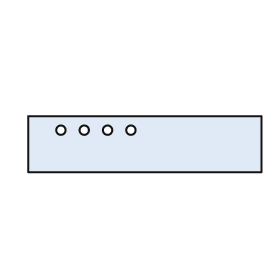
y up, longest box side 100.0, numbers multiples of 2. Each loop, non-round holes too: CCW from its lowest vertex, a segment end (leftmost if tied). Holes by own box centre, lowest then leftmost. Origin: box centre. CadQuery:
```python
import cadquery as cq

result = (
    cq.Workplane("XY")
    .moveTo(-50.0, -12.0)
    .lineTo(50.0, -12.0)
    .lineTo(50.0, 12.0)
    .lineTo(-50.0, 12.0)
    .close()
    .moveTo(-36.0, 6.0)
    .circle(2.0)
    .moveTo(-26.0, 6.0)
    .circle(2.0)
    .moveTo(-16.0, 6.0)
    .circle(2.0)
    .moveTo(-6.0, 6.0)
    .circle(2.0)
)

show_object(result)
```